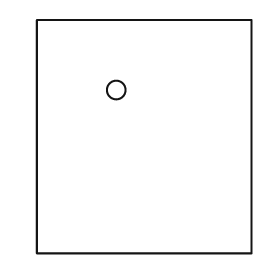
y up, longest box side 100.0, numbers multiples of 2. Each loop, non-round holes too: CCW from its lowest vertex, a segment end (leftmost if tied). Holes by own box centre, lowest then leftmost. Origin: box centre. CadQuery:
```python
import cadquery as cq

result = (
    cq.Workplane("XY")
    .moveTo(-46.0, -50.0)
    .lineTo(46.0, -50.0)
    .lineTo(46.0, 50.0)
    .lineTo(-46.0, 50.0)
    .close()
    .moveTo(-12.0, 20.0)
    .circle(4.0)
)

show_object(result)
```